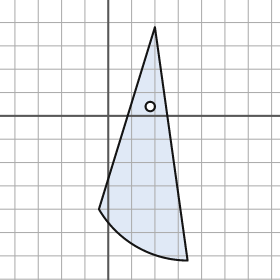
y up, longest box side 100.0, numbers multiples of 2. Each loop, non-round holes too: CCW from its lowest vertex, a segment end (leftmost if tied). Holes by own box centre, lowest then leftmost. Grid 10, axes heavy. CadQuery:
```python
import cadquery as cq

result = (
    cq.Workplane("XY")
    .moveTo(34.0, -62.0)
    .lineTo(20.0, 38.0)
    .lineTo(-4.0, -40.0)
    .threePointArc((12.0, -56.0), (34.0, -62.0))
    .close()
    .moveTo(18.0, 4.0)
    .circle(2.0)
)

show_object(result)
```